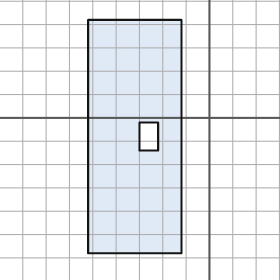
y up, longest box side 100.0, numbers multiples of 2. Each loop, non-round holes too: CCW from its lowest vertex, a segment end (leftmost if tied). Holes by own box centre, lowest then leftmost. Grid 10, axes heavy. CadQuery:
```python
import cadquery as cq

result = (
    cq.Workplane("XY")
    .moveTo(-52.0, -58.0)
    .lineTo(-12.0, -58.0)
    .lineTo(-12.0, 42.0)
    .lineTo(-52.0, 42.0)
    .close()
    .moveTo(-30.0, -14.0)
    .lineTo(-22.0, -14.0)
    .lineTo(-22.0, -2.0)
    .lineTo(-30.0, -2.0)
    .close()
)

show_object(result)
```